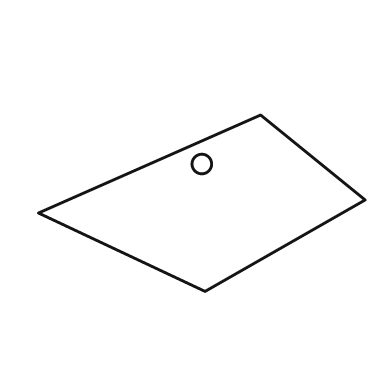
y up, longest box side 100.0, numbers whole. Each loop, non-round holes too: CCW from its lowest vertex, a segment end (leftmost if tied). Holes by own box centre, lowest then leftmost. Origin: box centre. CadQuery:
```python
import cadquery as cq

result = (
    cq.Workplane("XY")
    .moveTo(1.0, -27.0)
    .lineTo(50.0, 1.0)
    .lineTo(18.0, 27.0)
    .lineTo(-50.0, -3.0)
    .close()
    .moveTo(0.0, 12.0)
    .circle(3.0)
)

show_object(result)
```